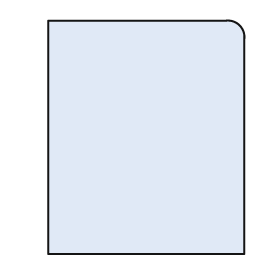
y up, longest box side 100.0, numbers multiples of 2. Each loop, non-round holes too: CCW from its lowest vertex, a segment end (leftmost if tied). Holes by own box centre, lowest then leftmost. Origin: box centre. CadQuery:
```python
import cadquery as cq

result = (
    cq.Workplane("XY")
    .moveTo(-42.0, -50.0)
    .lineTo(42.0, -50.0)
    .lineTo(42.0, 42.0)
    .threePointArc((40.0, 48.0), (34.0, 50.0))
    .lineTo(-42.0, 50.0)
    .close()
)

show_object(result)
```